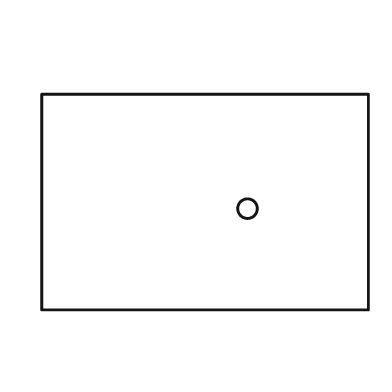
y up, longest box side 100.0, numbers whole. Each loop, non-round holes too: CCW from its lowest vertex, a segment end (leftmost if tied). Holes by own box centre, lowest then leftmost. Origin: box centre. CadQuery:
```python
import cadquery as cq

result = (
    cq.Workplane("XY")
    .moveTo(-50.0, -33.0)
    .lineTo(50.0, -33.0)
    .lineTo(50.0, 33.0)
    .lineTo(-50.0, 33.0)
    .close()
    .moveTo(13.0, -2.0)
    .circle(3.0)
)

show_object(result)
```